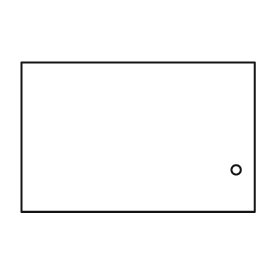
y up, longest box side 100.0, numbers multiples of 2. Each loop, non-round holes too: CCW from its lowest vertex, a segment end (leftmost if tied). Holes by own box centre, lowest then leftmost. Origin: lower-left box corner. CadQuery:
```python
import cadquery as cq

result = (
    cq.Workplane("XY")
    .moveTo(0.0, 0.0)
    .lineTo(100.0, 0.0)
    .lineTo(100.0, 64.0)
    .lineTo(0.0, 64.0)
    .close()
    .moveTo(92.0, 18.0)
    .circle(2.0)
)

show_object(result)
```